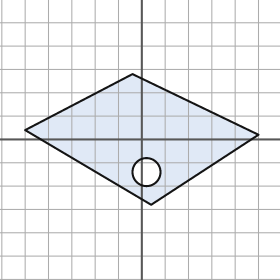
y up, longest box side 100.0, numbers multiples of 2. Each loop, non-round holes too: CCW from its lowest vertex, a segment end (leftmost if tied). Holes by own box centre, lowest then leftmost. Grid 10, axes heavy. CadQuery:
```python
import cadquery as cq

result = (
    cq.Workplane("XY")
    .moveTo(4.0, -28.0)
    .lineTo(50.0, 2.0)
    .lineTo(-4.0, 28.0)
    .lineTo(-50.0, 4.0)
    .close()
    .moveTo(2.0, -14.0)
    .circle(6.0)
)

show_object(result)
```